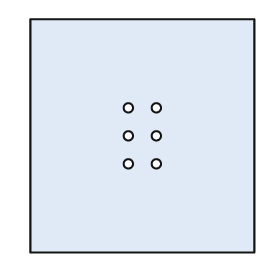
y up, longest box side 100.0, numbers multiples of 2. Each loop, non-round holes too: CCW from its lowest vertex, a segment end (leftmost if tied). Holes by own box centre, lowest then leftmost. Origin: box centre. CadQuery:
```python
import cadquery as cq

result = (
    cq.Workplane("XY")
    .moveTo(-48.0, -50.0)
    .lineTo(48.0, -50.0)
    .lineTo(48.0, 50.0)
    .lineTo(-48.0, 50.0)
    .close()
    .moveTo(-6.0, -12.0)
    .circle(2.0)
    .moveTo(6.0, -12.0)
    .circle(2.0)
    .moveTo(-6.0, 0.0)
    .circle(2.0)
    .moveTo(6.0, 0.0)
    .circle(2.0)
    .moveTo(-6.0, 12.0)
    .circle(2.0)
    .moveTo(6.0, 12.0)
    .circle(2.0)
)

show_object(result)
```